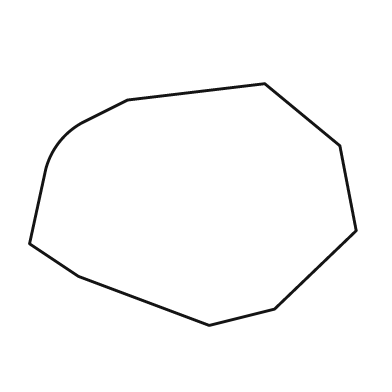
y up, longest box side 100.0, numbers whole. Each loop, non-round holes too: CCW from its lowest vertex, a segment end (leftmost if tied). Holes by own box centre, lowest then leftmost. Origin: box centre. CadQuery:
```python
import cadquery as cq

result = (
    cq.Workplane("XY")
    .moveTo(5.0, -37.0)
    .lineTo(25.0, -32.0)
    .lineTo(50.0, -8.0)
    .lineTo(45.0, 18.0)
    .lineTo(22.0, 37.0)
    .lineTo(-20.0, 32.0)
    .lineTo(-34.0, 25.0)
    .threePointArc((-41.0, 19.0), (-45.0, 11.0))
    .lineTo(-50.0, -12.0)
    .lineTo(-35.0, -22.0)
    .close()
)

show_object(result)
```